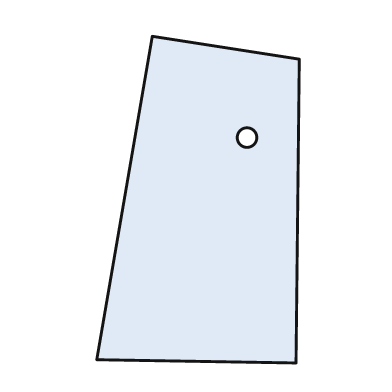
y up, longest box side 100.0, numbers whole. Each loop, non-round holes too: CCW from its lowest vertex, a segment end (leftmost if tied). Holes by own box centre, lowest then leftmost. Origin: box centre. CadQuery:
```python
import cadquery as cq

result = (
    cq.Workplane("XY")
    .moveTo(30.0, -50.0)
    .lineTo(31.0, 43.0)
    .lineTo(-14.0, 50.0)
    .lineTo(-31.0, -49.0)
    .close()
    .moveTo(15.0, 19.0)
    .circle(3.0)
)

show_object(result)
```